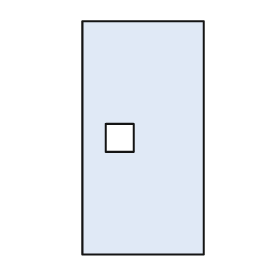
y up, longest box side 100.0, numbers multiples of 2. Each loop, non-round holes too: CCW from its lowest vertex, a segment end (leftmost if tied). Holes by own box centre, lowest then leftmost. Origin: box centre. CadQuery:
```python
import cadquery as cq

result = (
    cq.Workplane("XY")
    .moveTo(-26.0, -50.0)
    .lineTo(26.0, -50.0)
    .lineTo(26.0, 50.0)
    .lineTo(-26.0, 50.0)
    .close()
    .moveTo(-16.0, -6.0)
    .lineTo(-4.0, -6.0)
    .lineTo(-4.0, 6.0)
    .lineTo(-16.0, 6.0)
    .close()
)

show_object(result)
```